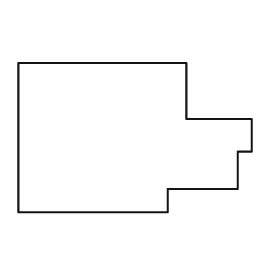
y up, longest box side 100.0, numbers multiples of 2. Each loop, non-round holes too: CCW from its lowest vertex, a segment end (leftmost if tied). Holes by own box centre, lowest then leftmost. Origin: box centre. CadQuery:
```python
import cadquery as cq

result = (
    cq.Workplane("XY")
    .moveTo(-50.0, -32.0)
    .lineTo(14.0, -32.0)
    .lineTo(14.0, -22.0)
    .lineTo(44.0, -22.0)
    .lineTo(44.0, -6.0)
    .lineTo(50.0, -6.0)
    .lineTo(50.0, 8.0)
    .lineTo(22.0, 8.0)
    .lineTo(22.0, 32.0)
    .lineTo(-50.0, 32.0)
    .close()
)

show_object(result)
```